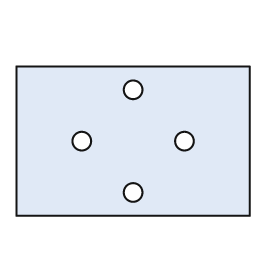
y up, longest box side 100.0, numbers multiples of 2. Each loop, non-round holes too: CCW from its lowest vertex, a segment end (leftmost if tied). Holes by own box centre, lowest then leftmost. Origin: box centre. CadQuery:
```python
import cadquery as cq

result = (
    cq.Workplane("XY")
    .moveTo(-50.0, -32.0)
    .lineTo(50.0, -32.0)
    .lineTo(50.0, 32.0)
    .lineTo(-50.0, 32.0)
    .close()
    .moveTo(0.0, -22.0)
    .circle(4.0)
    .moveTo(-22.0, 0.0)
    .circle(4.0)
    .moveTo(22.0, 0.0)
    .circle(4.0)
    .moveTo(0.0, 22.0)
    .circle(4.0)
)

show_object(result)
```